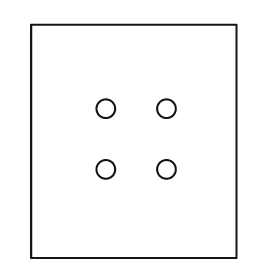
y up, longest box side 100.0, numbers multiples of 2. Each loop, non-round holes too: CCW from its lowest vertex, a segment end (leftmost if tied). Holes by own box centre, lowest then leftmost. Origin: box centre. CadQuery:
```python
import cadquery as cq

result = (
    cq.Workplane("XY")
    .moveTo(-44.0, -50.0)
    .lineTo(44.0, -50.0)
    .lineTo(44.0, 50.0)
    .lineTo(-44.0, 50.0)
    .close()
    .moveTo(-12.0, -12.0)
    .circle(4.0)
    .moveTo(14.0, -12.0)
    .circle(4.0)
    .moveTo(-12.0, 14.0)
    .circle(4.0)
    .moveTo(14.0, 14.0)
    .circle(4.0)
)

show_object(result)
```